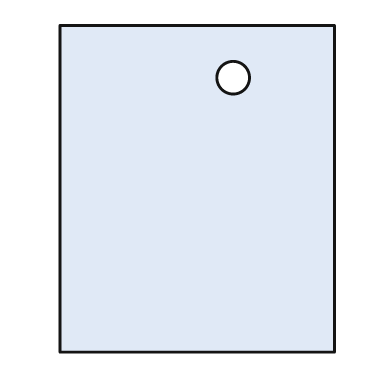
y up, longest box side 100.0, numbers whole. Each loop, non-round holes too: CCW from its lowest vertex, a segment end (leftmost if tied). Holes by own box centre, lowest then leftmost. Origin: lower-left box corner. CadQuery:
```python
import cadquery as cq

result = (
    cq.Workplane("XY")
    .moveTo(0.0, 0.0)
    .lineTo(84.0, 0.0)
    .lineTo(84.0, 100.0)
    .lineTo(0.0, 100.0)
    .close()
    .moveTo(53.0, 84.0)
    .circle(5.0)
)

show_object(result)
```